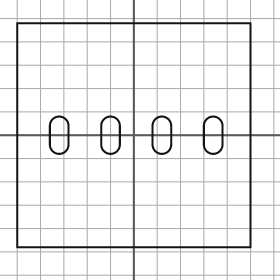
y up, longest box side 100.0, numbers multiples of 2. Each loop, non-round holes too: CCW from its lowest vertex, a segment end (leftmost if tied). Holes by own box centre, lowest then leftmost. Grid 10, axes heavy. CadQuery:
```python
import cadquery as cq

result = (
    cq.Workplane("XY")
    .moveTo(-50.0, -48.0)
    .lineTo(50.0, -48.0)
    .lineTo(50.0, 48.0)
    .lineTo(-50.0, 48.0)
    .close()
    .moveTo(-36.0, -4.0)
    .threePointArc((-32.0, -8.0), (-28.0, -4.0))
    .lineTo(-28.0, 4.0)
    .threePointArc((-32.0, 8.0), (-36.0, 4.0))
    .close()
    .moveTo(-14.0, -4.0)
    .threePointArc((-10.0, -8.0), (-6.0, -4.0))
    .lineTo(-6.0, 4.0)
    .threePointArc((-10.0, 8.0), (-14.0, 4.0))
    .close()
    .moveTo(8.0, -4.0)
    .threePointArc((12.0, -8.0), (16.0, -4.0))
    .lineTo(16.0, 4.0)
    .threePointArc((12.0, 8.0), (8.0, 4.0))
    .close()
    .moveTo(30.0, -4.0)
    .threePointArc((34.0, -8.0), (38.0, -4.0))
    .lineTo(38.0, 4.0)
    .threePointArc((34.0, 8.0), (30.0, 4.0))
    .close()
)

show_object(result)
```